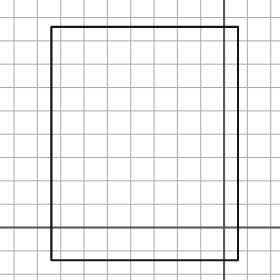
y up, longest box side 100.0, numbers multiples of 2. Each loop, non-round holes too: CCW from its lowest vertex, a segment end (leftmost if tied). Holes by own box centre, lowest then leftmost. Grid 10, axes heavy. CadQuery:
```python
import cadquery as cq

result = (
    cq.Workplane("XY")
    .moveTo(-74.0, -14.0)
    .lineTo(6.0, -14.0)
    .lineTo(6.0, 86.0)
    .lineTo(-74.0, 86.0)
    .close()
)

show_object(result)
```